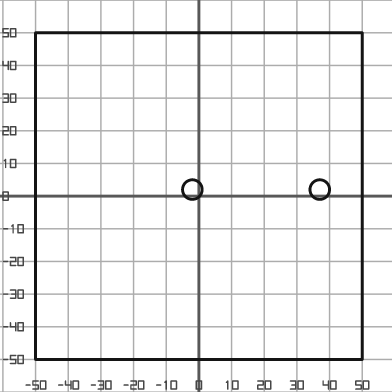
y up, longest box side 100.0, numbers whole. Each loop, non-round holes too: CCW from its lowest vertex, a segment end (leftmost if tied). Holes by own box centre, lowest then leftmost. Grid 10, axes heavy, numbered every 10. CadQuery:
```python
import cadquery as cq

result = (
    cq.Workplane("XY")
    .moveTo(-50.0, -50.0)
    .lineTo(50.0, -50.0)
    .lineTo(50.0, 50.0)
    .lineTo(-50.0, 50.0)
    .close()
    .moveTo(-2.0, 2.0)
    .circle(3.0)
    .moveTo(37.0, 2.0)
    .circle(3.0)
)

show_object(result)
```